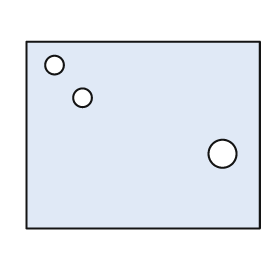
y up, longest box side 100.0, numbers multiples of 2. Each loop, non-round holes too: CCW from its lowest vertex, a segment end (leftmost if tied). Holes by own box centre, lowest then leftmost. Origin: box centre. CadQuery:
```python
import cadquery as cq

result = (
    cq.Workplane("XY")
    .moveTo(-50.0, -40.0)
    .lineTo(50.0, -40.0)
    .lineTo(50.0, 40.0)
    .lineTo(-50.0, 40.0)
    .close()
    .moveTo(34.0, -8.0)
    .circle(6.0)
    .moveTo(-26.0, 16.0)
    .circle(4.0)
    .moveTo(-38.0, 30.0)
    .circle(4.0)
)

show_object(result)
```